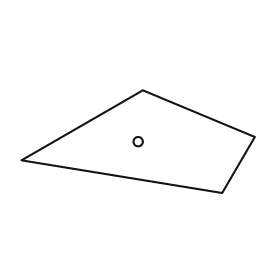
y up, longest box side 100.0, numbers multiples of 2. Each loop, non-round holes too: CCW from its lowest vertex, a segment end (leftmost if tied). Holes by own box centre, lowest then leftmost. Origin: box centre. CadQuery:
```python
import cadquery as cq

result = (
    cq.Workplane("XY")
    .moveTo(36.0, -22.0)
    .lineTo(50.0, 2.0)
    .lineTo(2.0, 22.0)
    .lineTo(-50.0, -8.0)
    .close()
    .moveTo(0.0, 0.0)
    .circle(2.0)
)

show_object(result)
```